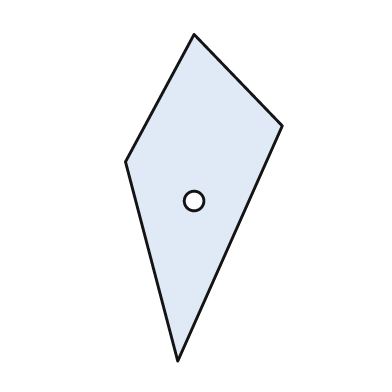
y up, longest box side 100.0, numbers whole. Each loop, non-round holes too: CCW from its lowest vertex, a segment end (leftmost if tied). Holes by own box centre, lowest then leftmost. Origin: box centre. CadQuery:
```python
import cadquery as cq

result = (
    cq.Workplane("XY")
    .moveTo(-8.0, -50.0)
    .lineTo(24.0, 22.0)
    .lineTo(-3.0, 50.0)
    .lineTo(-24.0, 11.0)
    .close()
    .moveTo(-3.0, -1.0)
    .circle(3.0)
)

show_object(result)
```